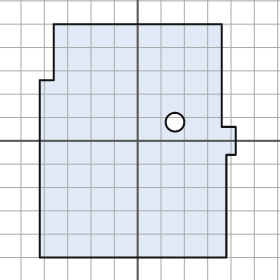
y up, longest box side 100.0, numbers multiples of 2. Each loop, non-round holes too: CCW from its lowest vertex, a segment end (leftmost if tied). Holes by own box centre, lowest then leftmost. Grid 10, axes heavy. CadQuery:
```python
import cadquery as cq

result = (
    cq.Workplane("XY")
    .moveTo(-42.0, -50.0)
    .lineTo(38.0, -50.0)
    .lineTo(38.0, -6.0)
    .lineTo(42.0, -6.0)
    .lineTo(42.0, 6.0)
    .lineTo(36.0, 6.0)
    .lineTo(36.0, 50.0)
    .lineTo(-36.0, 50.0)
    .lineTo(-36.0, 26.0)
    .lineTo(-42.0, 26.0)
    .close()
    .moveTo(16.0, 8.0)
    .circle(4.0)
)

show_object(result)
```